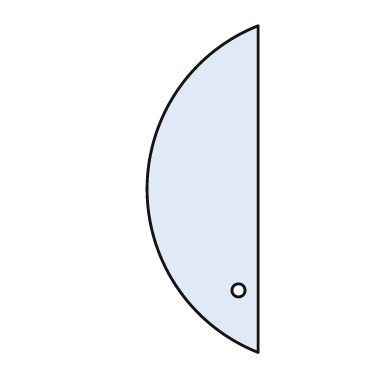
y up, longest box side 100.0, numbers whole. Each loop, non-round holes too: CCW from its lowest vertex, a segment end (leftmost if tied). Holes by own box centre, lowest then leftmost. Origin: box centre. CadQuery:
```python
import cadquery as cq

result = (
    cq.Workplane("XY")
    .moveTo(17.0, -50.0)
    .lineTo(17.0, 50.0)
    .threePointArc((-17.0, 0.0), (17.0, -50.0))
    .close()
    .moveTo(11.0, -31.0)
    .circle(2.0)
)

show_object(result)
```